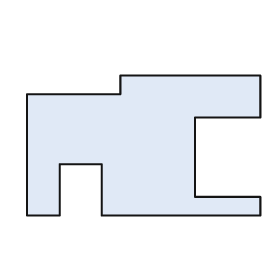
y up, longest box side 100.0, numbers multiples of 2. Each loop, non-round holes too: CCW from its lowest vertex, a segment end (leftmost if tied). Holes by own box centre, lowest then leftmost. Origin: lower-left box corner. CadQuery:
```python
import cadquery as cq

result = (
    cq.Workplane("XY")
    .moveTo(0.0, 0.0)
    .lineTo(14.0, 0.0)
    .lineTo(14.0, 22.0)
    .lineTo(32.0, 22.0)
    .lineTo(32.0, 0.0)
    .lineTo(100.0, 0.0)
    .lineTo(100.0, 8.0)
    .lineTo(72.0, 8.0)
    .lineTo(72.0, 42.0)
    .lineTo(100.0, 42.0)
    .lineTo(100.0, 60.0)
    .lineTo(40.0, 60.0)
    .lineTo(40.0, 52.0)
    .lineTo(0.0, 52.0)
    .close()
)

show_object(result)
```